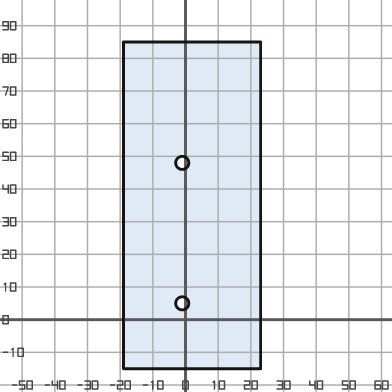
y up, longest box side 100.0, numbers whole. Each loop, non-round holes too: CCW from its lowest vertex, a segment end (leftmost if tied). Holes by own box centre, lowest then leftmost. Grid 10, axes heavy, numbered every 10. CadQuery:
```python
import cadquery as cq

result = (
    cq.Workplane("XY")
    .moveTo(-19.0, -15.0)
    .lineTo(23.0, -15.0)
    .lineTo(23.0, 85.0)
    .lineTo(-19.0, 85.0)
    .close()
    .moveTo(-1.0, 5.0)
    .circle(2.0)
    .moveTo(-1.0, 48.0)
    .circle(2.0)
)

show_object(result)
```